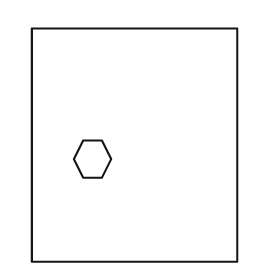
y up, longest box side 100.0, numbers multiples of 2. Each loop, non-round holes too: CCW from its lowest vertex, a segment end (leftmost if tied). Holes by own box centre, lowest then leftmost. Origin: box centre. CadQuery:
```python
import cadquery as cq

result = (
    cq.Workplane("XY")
    .moveTo(-44.0, -50.0)
    .lineTo(44.0, -50.0)
    .lineTo(44.0, 50.0)
    .lineTo(-44.0, 50.0)
    .close()
    .moveTo(-22.0, -14.0)
    .lineTo(-14.0, -14.0)
    .lineTo(-10.0, -6.0)
    .lineTo(-14.0, 2.0)
    .lineTo(-22.0, 2.0)
    .lineTo(-26.0, -6.0)
    .close()
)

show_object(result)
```